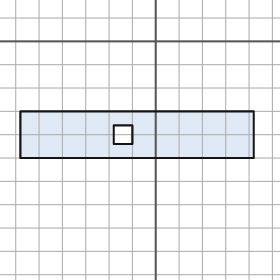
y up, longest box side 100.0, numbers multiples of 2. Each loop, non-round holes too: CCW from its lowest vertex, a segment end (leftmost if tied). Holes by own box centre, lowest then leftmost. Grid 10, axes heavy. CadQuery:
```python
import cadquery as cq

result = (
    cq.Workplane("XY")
    .moveTo(-58.0, -50.0)
    .lineTo(42.0, -50.0)
    .lineTo(42.0, -30.0)
    .lineTo(-58.0, -30.0)
    .close()
    .moveTo(-18.0, -44.0)
    .lineTo(-10.0, -44.0)
    .lineTo(-10.0, -36.0)
    .lineTo(-18.0, -36.0)
    .close()
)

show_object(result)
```